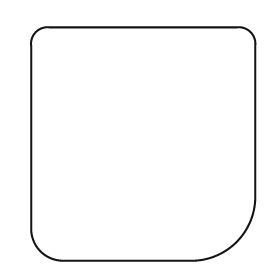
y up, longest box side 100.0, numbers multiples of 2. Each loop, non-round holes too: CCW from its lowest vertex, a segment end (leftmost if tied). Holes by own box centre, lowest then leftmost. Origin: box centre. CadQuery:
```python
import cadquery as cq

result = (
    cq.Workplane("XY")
    .moveTo(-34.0, -50.0)
    .lineTo(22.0, -50.0)
    .threePointArc((40.0, -42.0), (48.0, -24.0))
    .lineTo(48.0, 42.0)
    .threePointArc((46.0, 48.0), (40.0, 50.0))
    .lineTo(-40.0, 50.0)
    .threePointArc((-46.0, 48.0), (-48.0, 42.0))
    .lineTo(-48.0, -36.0)
    .threePointArc((-44.0, -46.0), (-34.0, -50.0))
    .close()
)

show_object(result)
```